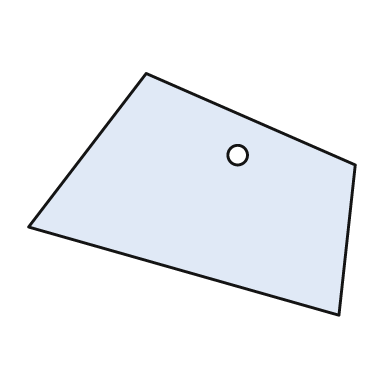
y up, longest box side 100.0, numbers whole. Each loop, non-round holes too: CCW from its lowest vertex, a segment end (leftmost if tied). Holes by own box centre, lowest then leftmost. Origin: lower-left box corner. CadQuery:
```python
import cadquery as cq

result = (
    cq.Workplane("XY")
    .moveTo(95.0, 0.0)
    .lineTo(100.0, 46.0)
    .lineTo(36.0, 74.0)
    .lineTo(0.0, 27.0)
    .close()
    .moveTo(64.0, 49.0)
    .circle(3.0)
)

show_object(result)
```